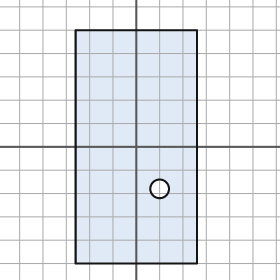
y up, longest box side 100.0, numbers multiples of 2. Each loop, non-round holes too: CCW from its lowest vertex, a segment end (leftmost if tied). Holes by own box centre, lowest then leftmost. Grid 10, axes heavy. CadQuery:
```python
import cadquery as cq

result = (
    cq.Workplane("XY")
    .moveTo(-26.0, -50.0)
    .lineTo(26.0, -50.0)
    .lineTo(26.0, 50.0)
    .lineTo(-26.0, 50.0)
    .close()
    .moveTo(10.0, -18.0)
    .circle(4.0)
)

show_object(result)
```